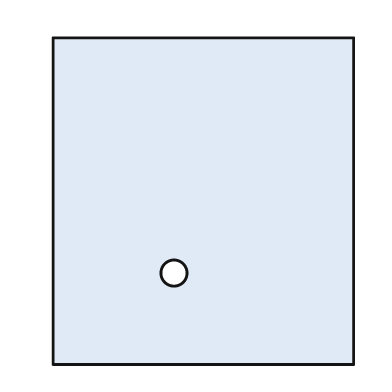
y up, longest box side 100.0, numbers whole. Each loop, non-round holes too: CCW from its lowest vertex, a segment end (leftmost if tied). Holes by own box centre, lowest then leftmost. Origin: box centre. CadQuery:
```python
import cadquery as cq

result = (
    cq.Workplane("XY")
    .moveTo(-46.0, -50.0)
    .lineTo(46.0, -50.0)
    .lineTo(46.0, 50.0)
    .lineTo(-46.0, 50.0)
    .close()
    .moveTo(-9.0, -22.0)
    .circle(4.0)
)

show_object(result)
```